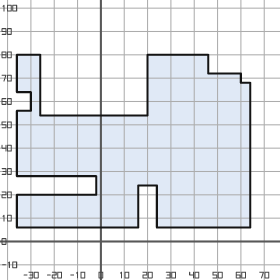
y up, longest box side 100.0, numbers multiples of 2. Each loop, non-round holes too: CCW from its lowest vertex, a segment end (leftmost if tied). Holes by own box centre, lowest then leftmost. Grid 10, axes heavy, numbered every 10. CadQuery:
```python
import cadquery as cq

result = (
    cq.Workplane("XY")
    .moveTo(-36.0, 6.0)
    .lineTo(16.0, 6.0)
    .lineTo(16.0, 24.0)
    .lineTo(24.0, 24.0)
    .lineTo(24.0, 6.0)
    .lineTo(64.0, 6.0)
    .lineTo(64.0, 68.0)
    .lineTo(60.0, 68.0)
    .lineTo(60.0, 72.0)
    .lineTo(46.0, 72.0)
    .lineTo(46.0, 80.0)
    .lineTo(20.0, 80.0)
    .lineTo(20.0, 54.0)
    .lineTo(-26.0, 54.0)
    .lineTo(-26.0, 80.0)
    .lineTo(-36.0, 80.0)
    .lineTo(-36.0, 64.0)
    .lineTo(-30.0, 64.0)
    .lineTo(-30.0, 56.0)
    .lineTo(-36.0, 56.0)
    .lineTo(-36.0, 28.0)
    .lineTo(-2.0, 28.0)
    .lineTo(-2.0, 20.0)
    .lineTo(-36.0, 20.0)
    .close()
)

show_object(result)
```